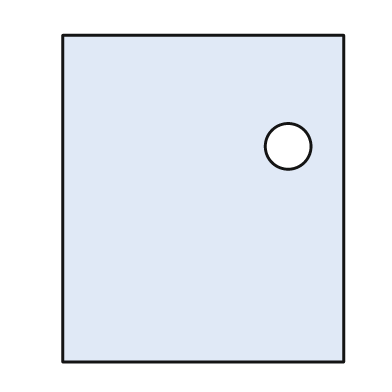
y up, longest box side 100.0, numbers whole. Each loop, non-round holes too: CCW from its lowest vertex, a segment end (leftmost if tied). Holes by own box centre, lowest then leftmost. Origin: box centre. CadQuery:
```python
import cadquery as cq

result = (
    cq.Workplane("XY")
    .moveTo(-43.0, -50.0)
    .lineTo(43.0, -50.0)
    .lineTo(43.0, 50.0)
    .lineTo(-43.0, 50.0)
    .close()
    .moveTo(26.0, 16.0)
    .circle(7.0)
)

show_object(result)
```